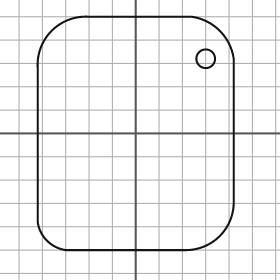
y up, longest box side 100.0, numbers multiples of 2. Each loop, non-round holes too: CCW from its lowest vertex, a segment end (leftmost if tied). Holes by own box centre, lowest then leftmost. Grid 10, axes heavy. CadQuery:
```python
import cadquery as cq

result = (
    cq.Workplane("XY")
    .moveTo(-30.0, -50.0)
    .lineTo(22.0, -50.0)
    .threePointArc((36.0, -44.0), (42.0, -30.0))
    .lineTo(42.0, 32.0)
    .threePointArc((36.0, 44.0), (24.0, 50.0))
    .lineTo(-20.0, 50.0)
    .threePointArc((-36.0, 44.0), (-42.0, 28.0))
    .lineTo(-42.0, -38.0)
    .threePointArc((-38.0, -46.0), (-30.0, -50.0))
    .close()
    .moveTo(30.0, 32.0)
    .circle(4.0)
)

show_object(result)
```